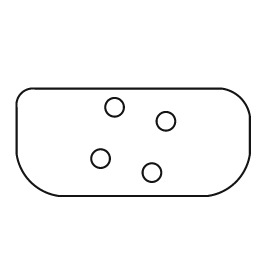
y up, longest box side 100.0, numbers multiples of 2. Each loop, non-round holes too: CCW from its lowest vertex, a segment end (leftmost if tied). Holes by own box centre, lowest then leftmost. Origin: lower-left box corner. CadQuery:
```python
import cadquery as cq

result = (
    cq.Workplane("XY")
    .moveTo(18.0, 0.0)
    .lineTo(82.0, 0.0)
    .threePointArc((94.0, 6.0), (100.0, 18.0))
    .lineTo(100.0, 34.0)
    .threePointArc((96.0, 42.0), (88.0, 46.0))
    .lineTo(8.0, 46.0)
    .threePointArc((2.0, 44.0), (0.0, 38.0))
    .lineTo(0.0, 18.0)
    .threePointArc((6.0, 6.0), (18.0, 0.0))
    .close()
    .moveTo(58.0, 10.0)
    .circle(4.0)
    .moveTo(36.0, 16.0)
    .circle(4.0)
    .moveTo(64.0, 32.0)
    .circle(4.0)
    .moveTo(42.0, 38.0)
    .circle(4.0)
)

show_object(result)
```